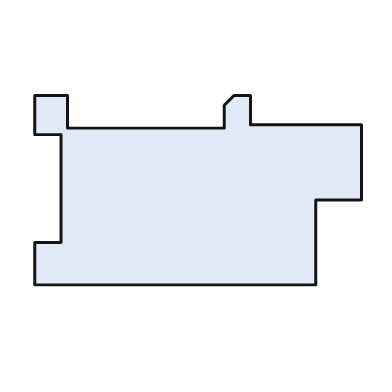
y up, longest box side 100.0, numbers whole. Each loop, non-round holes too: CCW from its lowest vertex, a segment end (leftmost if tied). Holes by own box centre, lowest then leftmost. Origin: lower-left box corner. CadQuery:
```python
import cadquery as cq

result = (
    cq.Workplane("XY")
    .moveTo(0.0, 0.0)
    .lineTo(86.0, 0.0)
    .lineTo(86.0, 26.0)
    .lineTo(100.0, 26.0)
    .lineTo(100.0, 49.0)
    .lineTo(66.0, 49.0)
    .lineTo(66.0, 58.0)
    .lineTo(61.0, 58.0)
    .lineTo(58.0, 55.0)
    .lineTo(58.0, 48.0)
    .lineTo(10.0, 48.0)
    .lineTo(10.0, 58.0)
    .lineTo(0.0, 58.0)
    .lineTo(0.0, 46.0)
    .lineTo(8.0, 46.0)
    .lineTo(8.0, 13.0)
    .lineTo(0.0, 13.0)
    .close()
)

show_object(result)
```